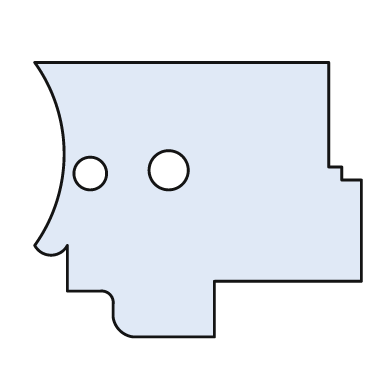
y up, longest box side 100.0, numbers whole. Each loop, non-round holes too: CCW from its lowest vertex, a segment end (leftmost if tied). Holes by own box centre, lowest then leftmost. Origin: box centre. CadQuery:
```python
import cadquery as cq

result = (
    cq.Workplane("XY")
    .moveTo(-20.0, -42.0)
    .lineTo(5.0, -42.0)
    .lineTo(5.0, -25.0)
    .lineTo(50.0, -25.0)
    .lineTo(50.0, 6.0)
    .lineTo(44.0, 6.0)
    .lineTo(44.0, 10.0)
    .lineTo(40.0, 10.0)
    .lineTo(40.0, 42.0)
    .lineTo(-50.0, 42.0)
    .threePointArc((-41.0, 14.0), (-50.0, -14.0))
    .threePointArc((-45.0, -17.0), (-40.0, -14.0))
    .lineTo(-40.0, -28.0)
    .lineTo(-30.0, -28.0)
    .threePointArc((-27.0, -29.0), (-26.0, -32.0))
    .lineTo(-26.0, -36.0)
    .threePointArc((-24.0, -40.0), (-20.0, -42.0))
    .close()
    .moveTo(-33.0, 8.0)
    .circle(5.0)
    .moveTo(-9.0, 9.0)
    .circle(6.0)
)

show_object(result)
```